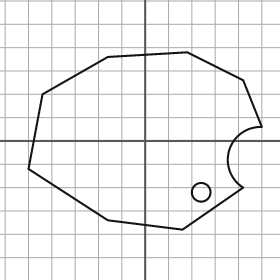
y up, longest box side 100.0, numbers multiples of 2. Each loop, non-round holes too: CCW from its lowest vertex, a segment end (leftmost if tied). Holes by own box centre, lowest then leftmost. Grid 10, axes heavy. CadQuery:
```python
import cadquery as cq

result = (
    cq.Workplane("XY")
    .moveTo(16.0, -38.0)
    .lineTo(42.0, -20.0)
    .threePointArc((36.0, -4.0), (50.0, 6.0))
    .lineTo(42.0, 26.0)
    .lineTo(18.0, 38.0)
    .lineTo(-16.0, 36.0)
    .lineTo(-44.0, 20.0)
    .lineTo(-50.0, -12.0)
    .lineTo(-16.0, -34.0)
    .close()
    .moveTo(24.0, -22.0)
    .circle(4.0)
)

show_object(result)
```